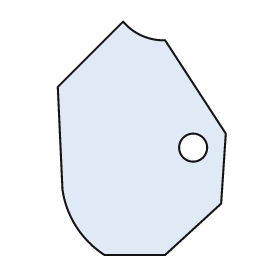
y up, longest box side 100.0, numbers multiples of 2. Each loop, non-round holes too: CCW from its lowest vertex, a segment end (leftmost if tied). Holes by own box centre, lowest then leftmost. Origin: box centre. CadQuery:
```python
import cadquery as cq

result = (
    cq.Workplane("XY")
    .moveTo(-16.0, -50.0)
    .lineTo(10.0, -50.0)
    .lineTo(34.0, -28.0)
    .lineTo(36.0, 2.0)
    .lineTo(10.0, 42.0)
    .threePointArc((0.0, 44.0), (-8.0, 50.0))
    .lineTo(-36.0, 22.0)
    .lineTo(-34.0, -22.0)
    .threePointArc((-28.0, -38.0), (-16.0, -50.0))
    .close()
    .moveTo(22.0, -4.0)
    .circle(6.0)
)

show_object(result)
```